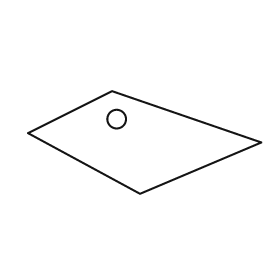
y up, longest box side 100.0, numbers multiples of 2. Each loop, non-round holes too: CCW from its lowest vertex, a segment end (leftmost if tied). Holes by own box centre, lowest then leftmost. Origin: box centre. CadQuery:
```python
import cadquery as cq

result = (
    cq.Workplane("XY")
    .moveTo(-2.0, -22.0)
    .lineTo(50.0, 0.0)
    .lineTo(-14.0, 22.0)
    .lineTo(-50.0, 4.0)
    .close()
    .moveTo(-12.0, 10.0)
    .circle(4.0)
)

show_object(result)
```